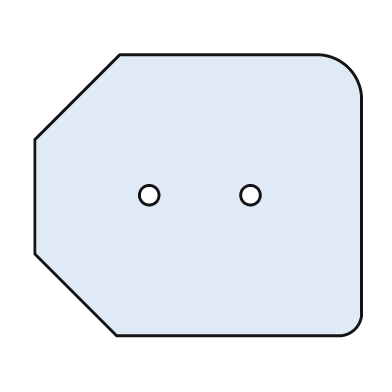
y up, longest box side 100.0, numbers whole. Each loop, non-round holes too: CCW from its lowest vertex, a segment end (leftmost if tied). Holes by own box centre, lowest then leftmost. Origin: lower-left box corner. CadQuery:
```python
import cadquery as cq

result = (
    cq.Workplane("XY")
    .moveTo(25.0, 0.0)
    .lineTo(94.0, 0.0)
    .threePointArc((98.0, 2.0), (100.0, 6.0))
    .lineTo(100.0, 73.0)
    .threePointArc((96.0, 82.0), (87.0, 86.0))
    .lineTo(26.0, 86.0)
    .lineTo(0.0, 60.0)
    .lineTo(0.0, 25.0)
    .close()
    .moveTo(35.0, 43.0)
    .circle(3.0)
    .moveTo(66.0, 43.0)
    .circle(3.0)
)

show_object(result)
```